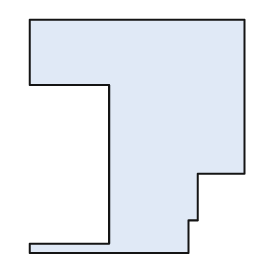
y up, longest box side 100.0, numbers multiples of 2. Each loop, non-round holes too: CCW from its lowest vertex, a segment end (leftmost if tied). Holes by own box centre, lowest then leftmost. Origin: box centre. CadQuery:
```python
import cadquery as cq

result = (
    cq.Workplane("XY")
    .moveTo(-46.0, -50.0)
    .lineTo(22.0, -50.0)
    .lineTo(22.0, -36.0)
    .lineTo(26.0, -36.0)
    .lineTo(26.0, -16.0)
    .lineTo(46.0, -16.0)
    .lineTo(46.0, 50.0)
    .lineTo(-46.0, 50.0)
    .lineTo(-46.0, 22.0)
    .lineTo(-12.0, 22.0)
    .lineTo(-12.0, -46.0)
    .lineTo(-46.0, -46.0)
    .close()
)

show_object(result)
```